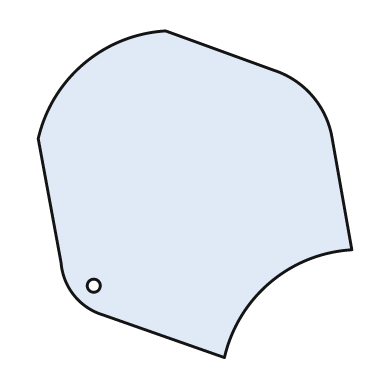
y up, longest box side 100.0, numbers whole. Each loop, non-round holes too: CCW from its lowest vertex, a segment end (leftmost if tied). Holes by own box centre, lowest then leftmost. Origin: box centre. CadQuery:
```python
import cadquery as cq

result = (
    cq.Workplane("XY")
    .moveTo(9.0, -50.0)
    .threePointArc((23.0, -27.0), (48.0, -17.0))
    .lineTo(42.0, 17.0)
    .threePointArc((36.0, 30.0), (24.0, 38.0))
    .lineTo(-9.0, 50.0)
    .threePointArc((-34.0, 40.0), (-48.0, 17.0))
    .lineTo(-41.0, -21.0)
    .threePointArc((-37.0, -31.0), (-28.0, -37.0))
    .close()
    .moveTo(-31.0, -28.0)
    .circle(2.0)
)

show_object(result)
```